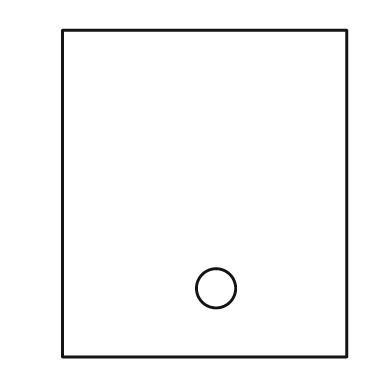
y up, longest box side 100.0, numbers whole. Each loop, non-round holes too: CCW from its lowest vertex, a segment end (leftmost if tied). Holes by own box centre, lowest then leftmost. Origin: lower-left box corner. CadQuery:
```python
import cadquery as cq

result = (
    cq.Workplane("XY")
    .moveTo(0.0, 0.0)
    .lineTo(87.0, 0.0)
    .lineTo(87.0, 100.0)
    .lineTo(0.0, 100.0)
    .close()
    .moveTo(47.0, 21.0)
    .circle(6.0)
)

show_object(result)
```